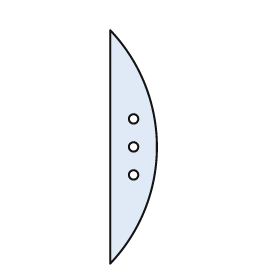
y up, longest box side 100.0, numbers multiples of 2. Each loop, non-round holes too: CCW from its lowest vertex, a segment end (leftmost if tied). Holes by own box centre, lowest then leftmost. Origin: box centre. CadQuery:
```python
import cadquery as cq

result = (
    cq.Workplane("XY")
    .moveTo(-10.0, -50.0)
    .threePointArc((10.0, 0.0), (-10.0, 50.0))
    .close()
    .moveTo(0.0, -12.0)
    .circle(2.0)
    .moveTo(0.0, 0.0)
    .circle(2.0)
    .moveTo(0.0, 12.0)
    .circle(2.0)
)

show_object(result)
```